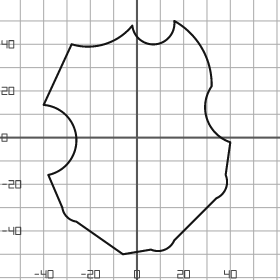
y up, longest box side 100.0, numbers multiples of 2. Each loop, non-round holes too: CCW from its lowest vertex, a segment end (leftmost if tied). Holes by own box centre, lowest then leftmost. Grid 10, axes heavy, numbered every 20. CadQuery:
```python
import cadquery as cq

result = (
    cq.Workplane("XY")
    .moveTo(-6.0, -50.0)
    .lineTo(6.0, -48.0)
    .threePointArc((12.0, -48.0), (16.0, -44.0))
    .lineTo(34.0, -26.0)
    .threePointArc((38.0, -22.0), (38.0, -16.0))
    .lineTo(40.0, -2.0)
    .threePointArc((30.0, 8.0), (32.0, 22.0))
    .threePointArc((28.0, 38.0), (16.0, 50.0))
    .threePointArc((8.0, 40.0), (-2.0, 48.0))
    .threePointArc((-14.0, 40.0), (-28.0, 40.0))
    .lineTo(-40.0, 14.0)
    .threePointArc((-26.0, 0.0), (-38.0, -16.0))
    .lineTo(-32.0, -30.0)
    .threePointArc((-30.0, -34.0), (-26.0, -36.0))
    .close()
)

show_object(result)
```